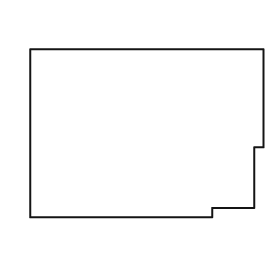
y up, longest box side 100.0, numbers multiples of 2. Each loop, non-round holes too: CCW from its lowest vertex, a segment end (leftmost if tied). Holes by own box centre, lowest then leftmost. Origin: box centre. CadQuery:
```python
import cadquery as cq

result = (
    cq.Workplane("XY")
    .moveTo(-50.0, -36.0)
    .lineTo(28.0, -36.0)
    .lineTo(28.0, -32.0)
    .lineTo(46.0, -32.0)
    .lineTo(46.0, -6.0)
    .lineTo(50.0, -6.0)
    .lineTo(50.0, 36.0)
    .lineTo(-50.0, 36.0)
    .close()
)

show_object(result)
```